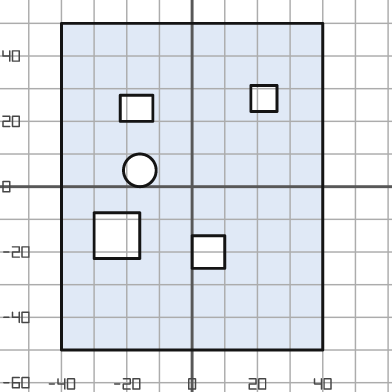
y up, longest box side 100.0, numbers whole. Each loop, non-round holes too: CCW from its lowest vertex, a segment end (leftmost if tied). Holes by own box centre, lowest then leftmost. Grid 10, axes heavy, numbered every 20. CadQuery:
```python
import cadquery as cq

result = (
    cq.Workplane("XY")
    .moveTo(-40.0, -50.0)
    .lineTo(40.0, -50.0)
    .lineTo(40.0, 50.0)
    .lineTo(-40.0, 50.0)
    .close()
    .moveTo(0.0, -25.0)
    .lineTo(10.0, -25.0)
    .lineTo(10.0, -15.0)
    .lineTo(0.0, -15.0)
    .close()
    .moveTo(-30.0, -22.0)
    .lineTo(-16.0, -22.0)
    .lineTo(-16.0, -8.0)
    .lineTo(-30.0, -8.0)
    .close()
    .moveTo(-16.0, 5.0)
    .circle(5.0)
    .moveTo(-22.0, 20.0)
    .lineTo(-12.0, 20.0)
    .lineTo(-12.0, 28.0)
    .lineTo(-22.0, 28.0)
    .close()
    .moveTo(18.0, 23.0)
    .lineTo(26.0, 23.0)
    .lineTo(26.0, 31.0)
    .lineTo(18.0, 31.0)
    .close()
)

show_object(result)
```